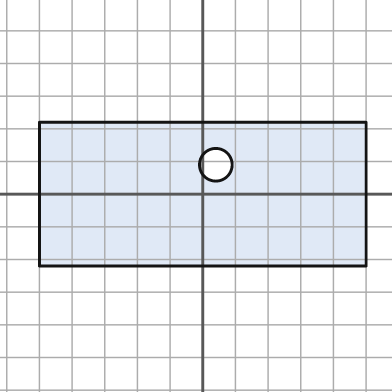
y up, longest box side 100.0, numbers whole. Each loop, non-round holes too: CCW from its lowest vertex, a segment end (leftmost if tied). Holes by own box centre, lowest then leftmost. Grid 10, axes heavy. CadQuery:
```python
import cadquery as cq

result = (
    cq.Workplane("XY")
    .moveTo(-50.0, -22.0)
    .lineTo(50.0, -22.0)
    .lineTo(50.0, 22.0)
    .lineTo(-50.0, 22.0)
    .close()
    .moveTo(4.0, 9.0)
    .circle(5.0)
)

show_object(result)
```